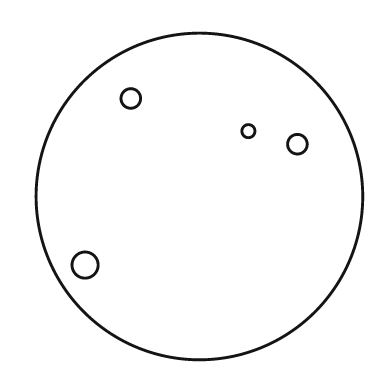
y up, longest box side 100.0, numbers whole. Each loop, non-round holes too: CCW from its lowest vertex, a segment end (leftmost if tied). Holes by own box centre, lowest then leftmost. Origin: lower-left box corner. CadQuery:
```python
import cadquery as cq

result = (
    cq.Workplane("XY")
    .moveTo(50.0, 50.0)
    .circle(50.0)
    .moveTo(15.0, 29.0)
    .circle(4.0)
    .moveTo(80.0, 66.0)
    .circle(3.0)
    .moveTo(65.0, 70.0)
    .circle(2.0)
    .moveTo(29.0, 80.0)
    .circle(3.0)
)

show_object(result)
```